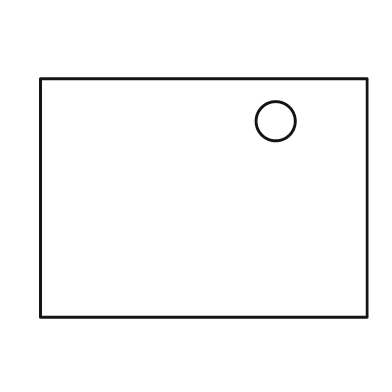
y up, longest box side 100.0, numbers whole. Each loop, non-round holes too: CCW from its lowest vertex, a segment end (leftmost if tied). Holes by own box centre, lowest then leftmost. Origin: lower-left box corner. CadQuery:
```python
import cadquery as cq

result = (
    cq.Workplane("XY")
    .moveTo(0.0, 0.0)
    .lineTo(100.0, 0.0)
    .lineTo(100.0, 73.0)
    .lineTo(0.0, 73.0)
    .close()
    .moveTo(72.0, 60.0)
    .circle(6.0)
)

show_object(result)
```